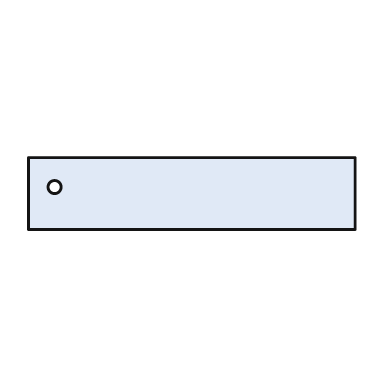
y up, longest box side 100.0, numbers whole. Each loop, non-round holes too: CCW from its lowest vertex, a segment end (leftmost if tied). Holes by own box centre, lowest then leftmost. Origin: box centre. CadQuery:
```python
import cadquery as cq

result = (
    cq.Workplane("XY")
    .moveTo(-50.0, -11.0)
    .lineTo(50.0, -11.0)
    .lineTo(50.0, 11.0)
    .lineTo(-50.0, 11.0)
    .close()
    .moveTo(-42.0, 2.0)
    .circle(2.0)
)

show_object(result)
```